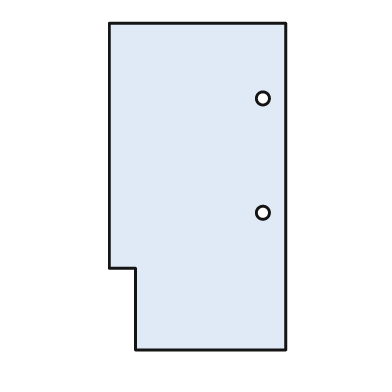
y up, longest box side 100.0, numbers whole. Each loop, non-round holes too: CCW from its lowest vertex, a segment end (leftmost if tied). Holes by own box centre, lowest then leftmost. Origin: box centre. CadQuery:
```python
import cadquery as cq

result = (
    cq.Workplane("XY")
    .moveTo(-19.0, -50.0)
    .lineTo(27.0, -50.0)
    .lineTo(27.0, 50.0)
    .lineTo(-27.0, 50.0)
    .lineTo(-27.0, -25.0)
    .lineTo(-19.0, -25.0)
    .close()
    .moveTo(20.0, -8.0)
    .circle(2.0)
    .moveTo(20.0, 27.0)
    .circle(2.0)
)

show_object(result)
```